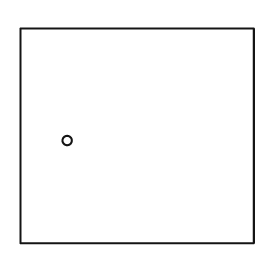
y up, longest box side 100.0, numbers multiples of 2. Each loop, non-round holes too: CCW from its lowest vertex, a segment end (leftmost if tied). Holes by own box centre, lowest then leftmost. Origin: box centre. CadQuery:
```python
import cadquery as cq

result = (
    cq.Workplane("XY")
    .moveTo(-50.0, -46.0)
    .lineTo(50.0, -46.0)
    .lineTo(50.0, 46.0)
    .lineTo(-50.0, 46.0)
    .close()
    .moveTo(-30.0, -2.0)
    .circle(2.0)
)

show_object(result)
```